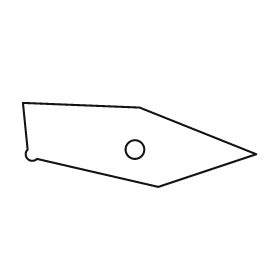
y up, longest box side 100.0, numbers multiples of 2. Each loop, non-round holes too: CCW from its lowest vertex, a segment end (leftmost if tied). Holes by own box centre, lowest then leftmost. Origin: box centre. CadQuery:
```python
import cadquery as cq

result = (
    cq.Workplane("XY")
    .moveTo(8.0, -18.0)
    .lineTo(50.0, -4.0)
    .lineTo(0.0, 16.0)
    .lineTo(-50.0, 18.0)
    .lineTo(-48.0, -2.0)
    .threePointArc((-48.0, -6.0), (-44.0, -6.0))
    .close()
    .moveTo(-2.0, -2.0)
    .circle(4.0)
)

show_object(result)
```